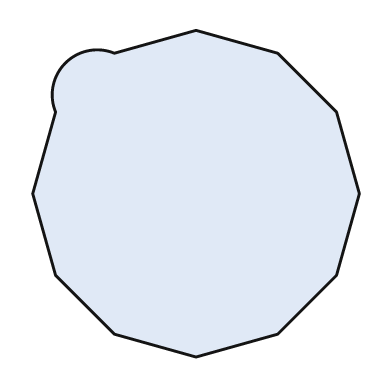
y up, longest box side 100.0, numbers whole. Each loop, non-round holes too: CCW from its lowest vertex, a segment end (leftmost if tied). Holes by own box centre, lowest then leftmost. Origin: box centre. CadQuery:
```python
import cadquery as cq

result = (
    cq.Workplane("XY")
    .moveTo(0.0, -50.0)
    .lineTo(25.0, -43.0)
    .lineTo(43.0, -25.0)
    .lineTo(50.0, 0.0)
    .lineTo(43.0, 25.0)
    .lineTo(25.0, 43.0)
    .lineTo(0.0, 50.0)
    .lineTo(-25.0, 43.0)
    .threePointArc((-40.0, 40.0), (-43.0, 25.0))
    .lineTo(-50.0, 0.0)
    .lineTo(-43.0, -25.0)
    .lineTo(-25.0, -43.0)
    .close()
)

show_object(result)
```